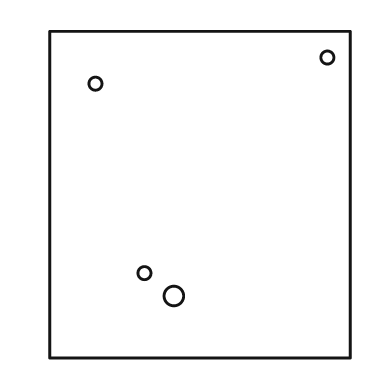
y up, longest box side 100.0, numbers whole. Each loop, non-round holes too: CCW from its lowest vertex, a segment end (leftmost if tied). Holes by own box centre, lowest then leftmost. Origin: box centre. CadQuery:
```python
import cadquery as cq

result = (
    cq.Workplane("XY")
    .moveTo(-46.0, -50.0)
    .lineTo(46.0, -50.0)
    .lineTo(46.0, 50.0)
    .lineTo(-46.0, 50.0)
    .close()
    .moveTo(-8.0, -31.0)
    .circle(3.0)
    .moveTo(-17.0, -24.0)
    .circle(2.0)
    .moveTo(-32.0, 34.0)
    .circle(2.0)
    .moveTo(39.0, 42.0)
    .circle(2.0)
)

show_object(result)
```